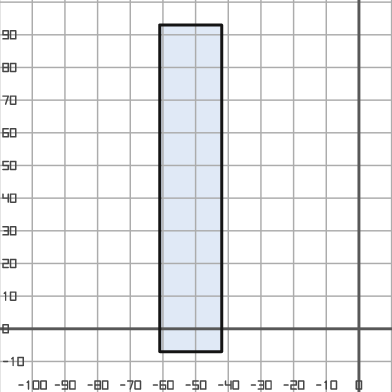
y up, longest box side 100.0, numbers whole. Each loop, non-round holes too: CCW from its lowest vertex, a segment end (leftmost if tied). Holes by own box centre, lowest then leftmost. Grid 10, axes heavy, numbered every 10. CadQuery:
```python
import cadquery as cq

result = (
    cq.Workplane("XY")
    .moveTo(-61.0, -7.0)
    .lineTo(-42.0, -7.0)
    .lineTo(-42.0, 93.0)
    .lineTo(-61.0, 93.0)
    .close()
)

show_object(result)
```